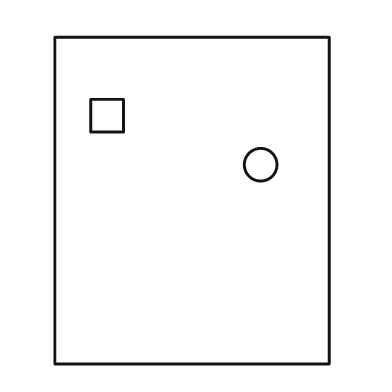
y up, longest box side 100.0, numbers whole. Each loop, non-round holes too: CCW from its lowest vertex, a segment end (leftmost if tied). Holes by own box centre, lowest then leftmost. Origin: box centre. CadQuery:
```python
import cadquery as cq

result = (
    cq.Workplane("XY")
    .moveTo(-42.0, -50.0)
    .lineTo(42.0, -50.0)
    .lineTo(42.0, 50.0)
    .lineTo(-42.0, 50.0)
    .close()
    .moveTo(21.0, 11.0)
    .circle(5.0)
    .moveTo(-31.0, 21.0)
    .lineTo(-21.0, 21.0)
    .lineTo(-21.0, 31.0)
    .lineTo(-31.0, 31.0)
    .close()
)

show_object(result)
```